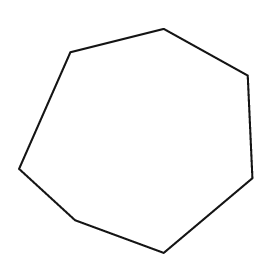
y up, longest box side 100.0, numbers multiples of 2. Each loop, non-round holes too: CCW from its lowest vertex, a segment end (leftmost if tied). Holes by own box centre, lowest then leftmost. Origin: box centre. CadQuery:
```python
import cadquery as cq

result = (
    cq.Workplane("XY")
    .moveTo(12.0, -48.0)
    .lineTo(50.0, -16.0)
    .lineTo(48.0, 28.0)
    .lineTo(12.0, 48.0)
    .lineTo(-28.0, 38.0)
    .lineTo(-50.0, -12.0)
    .lineTo(-26.0, -34.0)
    .close()
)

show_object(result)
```